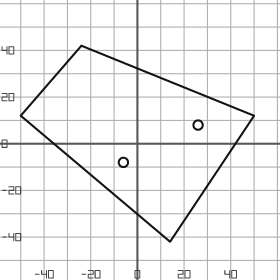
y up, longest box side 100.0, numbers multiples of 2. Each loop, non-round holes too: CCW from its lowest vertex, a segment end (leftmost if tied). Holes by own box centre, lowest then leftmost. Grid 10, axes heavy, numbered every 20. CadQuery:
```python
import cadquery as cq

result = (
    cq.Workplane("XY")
    .moveTo(14.0, -42.0)
    .lineTo(50.0, 12.0)
    .lineTo(-24.0, 42.0)
    .lineTo(-50.0, 12.0)
    .close()
    .moveTo(-6.0, -8.0)
    .circle(2.0)
    .moveTo(26.0, 8.0)
    .circle(2.0)
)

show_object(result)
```